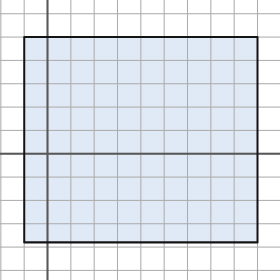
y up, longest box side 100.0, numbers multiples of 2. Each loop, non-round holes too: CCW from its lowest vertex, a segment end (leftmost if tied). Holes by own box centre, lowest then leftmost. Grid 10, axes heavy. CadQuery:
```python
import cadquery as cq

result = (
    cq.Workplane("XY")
    .moveTo(-10.0, -38.0)
    .lineTo(90.0, -38.0)
    .lineTo(90.0, 50.0)
    .lineTo(-10.0, 50.0)
    .close()
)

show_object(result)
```